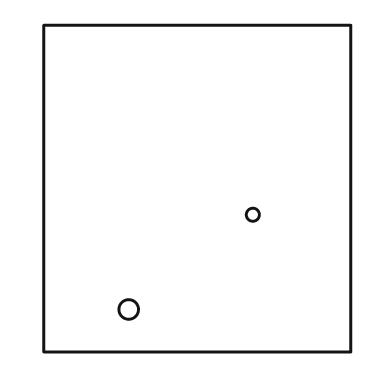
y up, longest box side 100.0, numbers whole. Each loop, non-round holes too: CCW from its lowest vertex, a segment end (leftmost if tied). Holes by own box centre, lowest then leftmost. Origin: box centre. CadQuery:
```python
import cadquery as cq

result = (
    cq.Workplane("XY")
    .moveTo(-47.0, -50.0)
    .lineTo(47.0, -50.0)
    .lineTo(47.0, 50.0)
    .lineTo(-47.0, 50.0)
    .close()
    .moveTo(-21.0, -37.0)
    .circle(3.0)
    .moveTo(17.0, -8.0)
    .circle(2.0)
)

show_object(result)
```